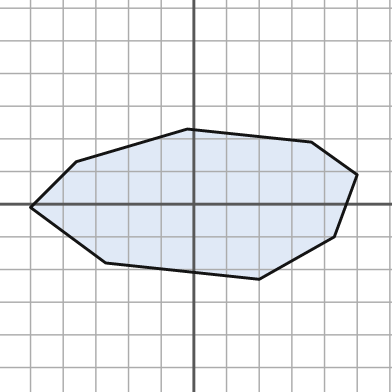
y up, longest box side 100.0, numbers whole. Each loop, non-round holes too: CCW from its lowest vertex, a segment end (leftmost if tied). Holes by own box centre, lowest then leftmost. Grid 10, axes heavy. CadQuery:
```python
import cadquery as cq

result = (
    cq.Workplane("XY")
    .moveTo(20.0, -23.0)
    .lineTo(43.0, -10.0)
    .lineTo(50.0, 9.0)
    .lineTo(36.0, 19.0)
    .lineTo(-2.0, 23.0)
    .lineTo(-36.0, 13.0)
    .lineTo(-50.0, -1.0)
    .lineTo(-27.0, -18.0)
    .close()
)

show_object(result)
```